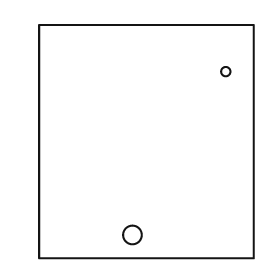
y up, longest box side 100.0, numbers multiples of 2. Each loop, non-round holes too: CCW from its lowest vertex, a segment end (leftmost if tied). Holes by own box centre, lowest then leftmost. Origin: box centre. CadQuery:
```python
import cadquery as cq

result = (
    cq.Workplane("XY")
    .moveTo(-46.0, -50.0)
    .lineTo(46.0, -50.0)
    .lineTo(46.0, 50.0)
    .lineTo(-46.0, 50.0)
    .close()
    .moveTo(-6.0, -40.0)
    .circle(4.0)
    .moveTo(34.0, 30.0)
    .circle(2.0)
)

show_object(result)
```